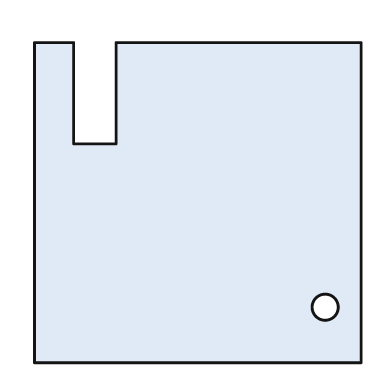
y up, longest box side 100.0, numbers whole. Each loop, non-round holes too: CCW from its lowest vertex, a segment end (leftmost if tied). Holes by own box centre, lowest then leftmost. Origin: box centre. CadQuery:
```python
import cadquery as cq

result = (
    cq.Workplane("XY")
    .moveTo(-50.0, -49.0)
    .lineTo(50.0, -49.0)
    .lineTo(50.0, 49.0)
    .lineTo(-25.0, 49.0)
    .lineTo(-25.0, 18.0)
    .lineTo(-38.0, 18.0)
    .lineTo(-38.0, 49.0)
    .lineTo(-50.0, 49.0)
    .close()
    .moveTo(39.0, -32.0)
    .circle(4.0)
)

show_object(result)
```